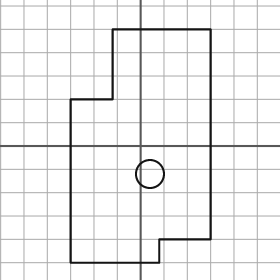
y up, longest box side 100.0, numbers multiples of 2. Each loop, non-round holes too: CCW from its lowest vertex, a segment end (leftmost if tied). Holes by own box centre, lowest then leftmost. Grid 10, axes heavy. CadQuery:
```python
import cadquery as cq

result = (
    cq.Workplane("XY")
    .moveTo(-30.0, -50.0)
    .lineTo(8.0, -50.0)
    .lineTo(8.0, -40.0)
    .lineTo(30.0, -40.0)
    .lineTo(30.0, 50.0)
    .lineTo(-12.0, 50.0)
    .lineTo(-12.0, 20.0)
    .lineTo(-30.0, 20.0)
    .close()
    .moveTo(4.0, -12.0)
    .circle(6.0)
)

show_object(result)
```